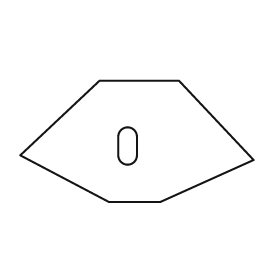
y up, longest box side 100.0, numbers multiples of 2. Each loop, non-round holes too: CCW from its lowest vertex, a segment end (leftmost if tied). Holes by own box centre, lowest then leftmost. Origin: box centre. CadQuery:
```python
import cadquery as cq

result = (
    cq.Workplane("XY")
    .moveTo(-12.0, -26.0)
    .lineTo(10.0, -26.0)
    .lineTo(50.0, -8.0)
    .lineTo(18.0, 26.0)
    .lineTo(-16.0, 26.0)
    .lineTo(-50.0, -6.0)
    .close()
    .moveTo(-8.0, -6.0)
    .threePointArc((-4.0, -10.0), (0.0, -6.0))
    .lineTo(0.0, 2.0)
    .threePointArc((-4.0, 6.0), (-8.0, 2.0))
    .close()
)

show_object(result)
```